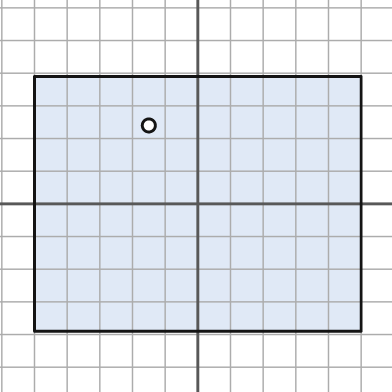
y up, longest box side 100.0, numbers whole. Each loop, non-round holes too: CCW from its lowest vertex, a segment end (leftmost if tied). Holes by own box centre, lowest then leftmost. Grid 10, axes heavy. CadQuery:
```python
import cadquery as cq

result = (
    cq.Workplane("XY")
    .moveTo(-50.0, -39.0)
    .lineTo(50.0, -39.0)
    .lineTo(50.0, 39.0)
    .lineTo(-50.0, 39.0)
    .close()
    .moveTo(-15.0, 24.0)
    .circle(2.0)
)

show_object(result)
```